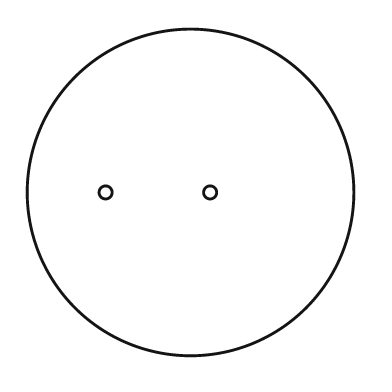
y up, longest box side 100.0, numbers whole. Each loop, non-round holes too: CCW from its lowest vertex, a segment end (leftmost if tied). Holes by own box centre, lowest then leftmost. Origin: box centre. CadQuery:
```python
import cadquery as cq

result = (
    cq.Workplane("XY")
    .moveTo(0.0, 0.0)
    .circle(50.0)
    .moveTo(-26.0, 0.0)
    .circle(2.0)
    .moveTo(6.0, 0.0)
    .circle(2.0)
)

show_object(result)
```